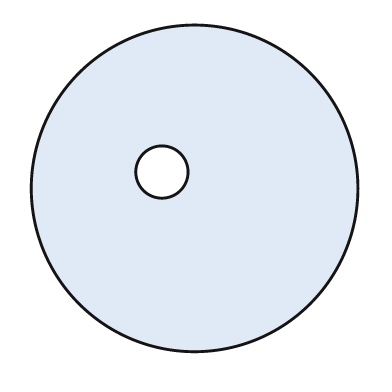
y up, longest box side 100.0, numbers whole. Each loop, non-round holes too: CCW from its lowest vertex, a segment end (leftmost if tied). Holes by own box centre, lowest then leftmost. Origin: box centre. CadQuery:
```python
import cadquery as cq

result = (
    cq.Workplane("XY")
    .moveTo(0.0, 0.0)
    .circle(50.0)
    .moveTo(-10.0, 5.0)
    .circle(8.0)
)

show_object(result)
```